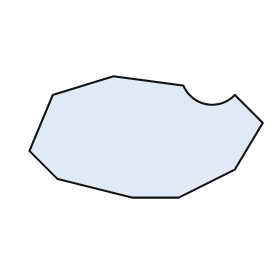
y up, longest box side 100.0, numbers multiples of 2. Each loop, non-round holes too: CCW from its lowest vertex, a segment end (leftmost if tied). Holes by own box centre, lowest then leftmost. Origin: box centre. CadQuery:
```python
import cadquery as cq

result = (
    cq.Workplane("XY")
    .moveTo(-6.0, -26.0)
    .lineTo(14.0, -26.0)
    .lineTo(38.0, -14.0)
    .lineTo(50.0, 6.0)
    .lineTo(38.0, 18.0)
    .threePointArc((26.0, 14.0), (16.0, 22.0))
    .lineTo(-14.0, 26.0)
    .lineTo(-40.0, 18.0)
    .lineTo(-50.0, -6.0)
    .lineTo(-38.0, -18.0)
    .close()
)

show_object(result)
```